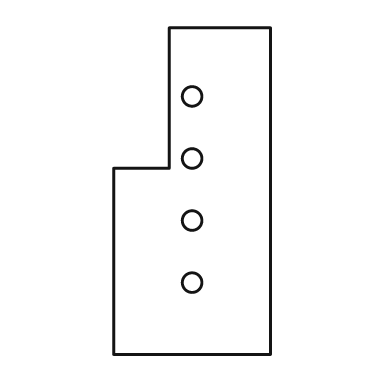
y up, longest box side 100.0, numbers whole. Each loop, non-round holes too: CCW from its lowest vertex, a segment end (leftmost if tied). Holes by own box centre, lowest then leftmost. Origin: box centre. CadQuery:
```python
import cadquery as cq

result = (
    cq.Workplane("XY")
    .moveTo(-24.0, -50.0)
    .lineTo(24.0, -50.0)
    .lineTo(24.0, 50.0)
    .lineTo(-7.0, 50.0)
    .lineTo(-7.0, 7.0)
    .lineTo(-24.0, 7.0)
    .close()
    .moveTo(0.0, -28.0)
    .circle(3.0)
    .moveTo(0.0, -9.0)
    .circle(3.0)
    .moveTo(0.0, 10.0)
    .circle(3.0)
    .moveTo(0.0, 29.0)
    .circle(3.0)
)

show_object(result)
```